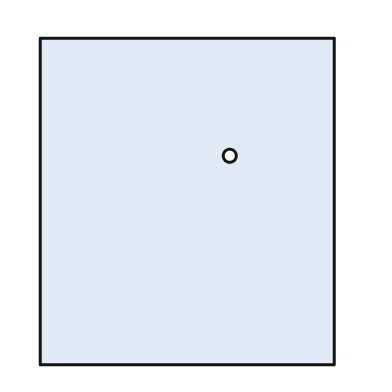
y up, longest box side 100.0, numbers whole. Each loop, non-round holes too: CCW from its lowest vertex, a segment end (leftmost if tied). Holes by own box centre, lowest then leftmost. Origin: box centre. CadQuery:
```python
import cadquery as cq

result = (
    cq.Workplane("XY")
    .moveTo(-45.0, -50.0)
    .lineTo(45.0, -50.0)
    .lineTo(45.0, 50.0)
    .lineTo(-45.0, 50.0)
    .close()
    .moveTo(13.0, 14.0)
    .circle(2.0)
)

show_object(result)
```